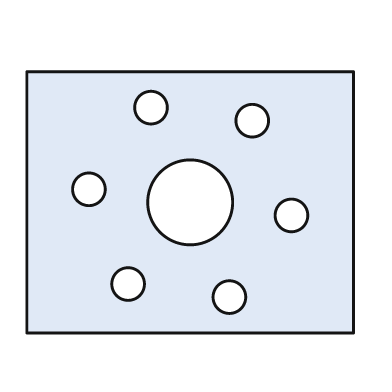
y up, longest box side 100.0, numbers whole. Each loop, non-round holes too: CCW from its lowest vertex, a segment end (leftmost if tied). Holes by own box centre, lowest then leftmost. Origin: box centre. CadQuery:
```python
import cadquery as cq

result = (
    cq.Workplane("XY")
    .moveTo(-50.0, -40.0)
    .lineTo(50.0, -40.0)
    .lineTo(50.0, 40.0)
    .lineTo(-50.0, 40.0)
    .close()
    .moveTo(12.0, -29.0)
    .circle(5.0)
    .moveTo(-19.0, -25.0)
    .circle(5.0)
    .moveTo(31.0, -4.0)
    .circle(5.0)
    .moveTo(0.0, 0.0)
    .circle(13.0)
    .moveTo(-31.0, 4.0)
    .circle(5.0)
    .moveTo(19.0, 25.0)
    .circle(5.0)
    .moveTo(-12.0, 29.0)
    .circle(5.0)
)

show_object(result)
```